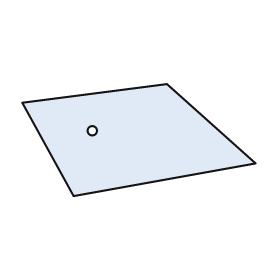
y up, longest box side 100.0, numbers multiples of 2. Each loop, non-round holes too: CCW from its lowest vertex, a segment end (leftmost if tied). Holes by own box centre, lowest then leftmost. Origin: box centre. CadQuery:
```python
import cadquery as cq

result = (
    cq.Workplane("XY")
    .moveTo(-28.0, -24.0)
    .lineTo(50.0, -10.0)
    .lineTo(12.0, 24.0)
    .lineTo(-50.0, 16.0)
    .close()
    .moveTo(-20.0, 4.0)
    .circle(2.0)
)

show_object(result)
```